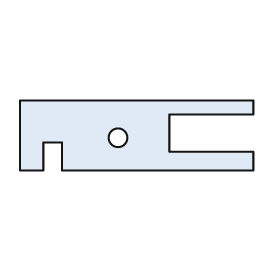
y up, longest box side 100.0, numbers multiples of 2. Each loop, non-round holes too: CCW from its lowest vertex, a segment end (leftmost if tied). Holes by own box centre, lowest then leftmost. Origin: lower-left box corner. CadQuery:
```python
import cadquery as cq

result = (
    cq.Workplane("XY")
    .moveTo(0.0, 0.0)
    .lineTo(10.0, 0.0)
    .lineTo(10.0, 12.0)
    .lineTo(18.0, 12.0)
    .lineTo(18.0, 0.0)
    .lineTo(100.0, 0.0)
    .lineTo(100.0, 8.0)
    .lineTo(64.0, 8.0)
    .lineTo(64.0, 24.0)
    .lineTo(100.0, 24.0)
    .lineTo(100.0, 30.0)
    .lineTo(0.0, 30.0)
    .close()
    .moveTo(42.0, 14.0)
    .circle(4.0)
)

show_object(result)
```